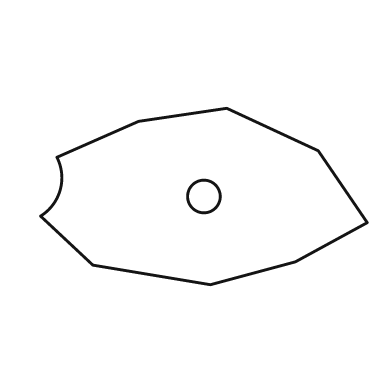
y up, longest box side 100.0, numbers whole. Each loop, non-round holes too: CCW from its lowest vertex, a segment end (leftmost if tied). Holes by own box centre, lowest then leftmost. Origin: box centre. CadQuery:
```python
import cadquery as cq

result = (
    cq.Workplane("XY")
    .moveTo(2.0, -27.0)
    .lineTo(28.0, -20.0)
    .lineTo(50.0, -8.0)
    .lineTo(35.0, 14.0)
    .lineTo(7.0, 27.0)
    .lineTo(-20.0, 23.0)
    .lineTo(-45.0, 12.0)
    .threePointArc((-44.0, 2.0), (-50.0, -6.0))
    .lineTo(-34.0, -21.0)
    .close()
    .moveTo(0.0, 0.0)
    .circle(5.0)
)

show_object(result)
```